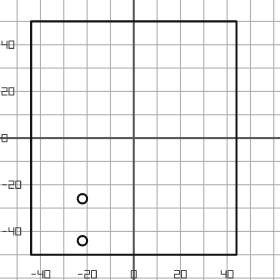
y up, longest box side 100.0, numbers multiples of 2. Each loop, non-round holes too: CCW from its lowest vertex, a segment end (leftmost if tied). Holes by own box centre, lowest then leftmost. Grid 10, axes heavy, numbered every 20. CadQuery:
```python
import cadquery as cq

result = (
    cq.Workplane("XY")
    .moveTo(-44.0, -50.0)
    .lineTo(44.0, -50.0)
    .lineTo(44.0, 50.0)
    .lineTo(-44.0, 50.0)
    .close()
    .moveTo(-22.0, -44.0)
    .circle(2.0)
    .moveTo(-22.0, -26.0)
    .circle(2.0)
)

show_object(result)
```